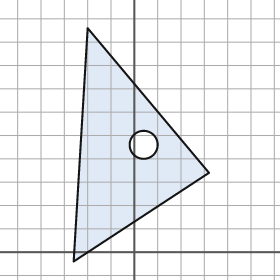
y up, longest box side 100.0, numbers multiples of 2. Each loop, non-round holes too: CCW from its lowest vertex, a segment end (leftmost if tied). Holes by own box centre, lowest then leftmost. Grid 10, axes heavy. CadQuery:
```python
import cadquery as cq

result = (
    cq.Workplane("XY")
    .moveTo(-26.0, -4.0)
    .lineTo(32.0, 34.0)
    .lineTo(-20.0, 96.0)
    .close()
    .moveTo(4.0, 46.0)
    .circle(6.0)
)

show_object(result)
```